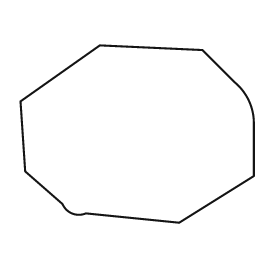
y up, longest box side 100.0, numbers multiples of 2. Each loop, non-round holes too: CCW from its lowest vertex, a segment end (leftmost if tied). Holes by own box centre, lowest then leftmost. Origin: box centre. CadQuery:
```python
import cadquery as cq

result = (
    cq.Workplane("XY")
    .moveTo(18.0, -38.0)
    .lineTo(50.0, -18.0)
    .lineTo(50.0, 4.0)
    .threePointArc((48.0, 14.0), (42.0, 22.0))
    .lineTo(28.0, 36.0)
    .lineTo(-16.0, 38.0)
    .lineTo(-50.0, 14.0)
    .lineTo(-48.0, -16.0)
    .lineTo(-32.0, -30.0)
    .threePointArc((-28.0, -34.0), (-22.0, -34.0))
    .close()
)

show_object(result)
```